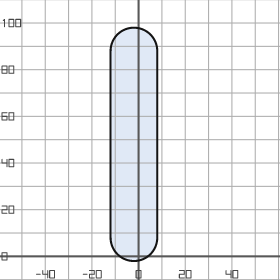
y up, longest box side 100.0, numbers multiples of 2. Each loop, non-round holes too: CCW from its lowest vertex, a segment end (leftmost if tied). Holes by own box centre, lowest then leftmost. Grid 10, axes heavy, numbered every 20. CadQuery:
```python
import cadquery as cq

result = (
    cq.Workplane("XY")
    .moveTo(-12.0, 8.0)
    .threePointArc((-2.0, -2.0), (8.0, 8.0))
    .lineTo(8.0, 88.0)
    .threePointArc((-2.0, 98.0), (-12.0, 88.0))
    .close()
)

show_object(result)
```